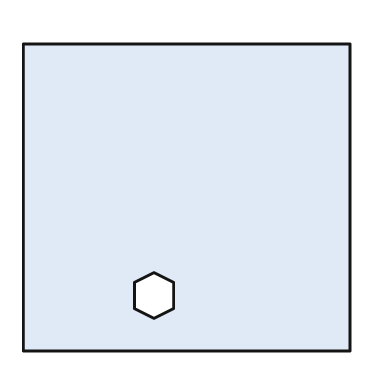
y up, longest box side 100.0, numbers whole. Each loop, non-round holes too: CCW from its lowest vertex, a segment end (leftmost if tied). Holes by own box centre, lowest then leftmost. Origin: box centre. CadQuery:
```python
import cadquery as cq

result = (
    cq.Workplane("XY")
    .moveTo(-50.0, -47.0)
    .lineTo(50.0, -47.0)
    .lineTo(50.0, 47.0)
    .lineTo(-50.0, 47.0)
    .close()
    .moveTo(-10.0, -37.0)
    .lineTo(-4.0, -34.0)
    .lineTo(-4.0, -26.0)
    .lineTo(-10.0, -23.0)
    .lineTo(-16.0, -26.0)
    .lineTo(-16.0, -34.0)
    .close()
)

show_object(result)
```